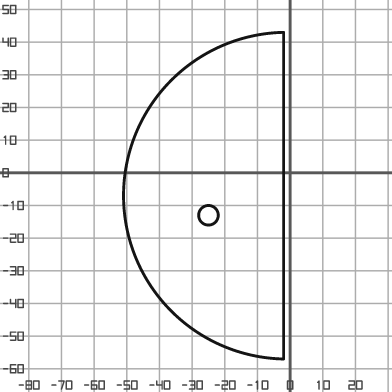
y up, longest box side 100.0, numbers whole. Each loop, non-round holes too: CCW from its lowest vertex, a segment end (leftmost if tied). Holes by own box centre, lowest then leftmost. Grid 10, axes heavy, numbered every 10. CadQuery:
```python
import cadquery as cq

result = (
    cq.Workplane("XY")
    .moveTo(-2.0, -57.0)
    .lineTo(-2.0, 43.0)
    .threePointArc((-51.0, -7.0), (-2.0, -57.0))
    .close()
    .moveTo(-25.0, -13.0)
    .circle(3.0)
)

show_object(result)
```